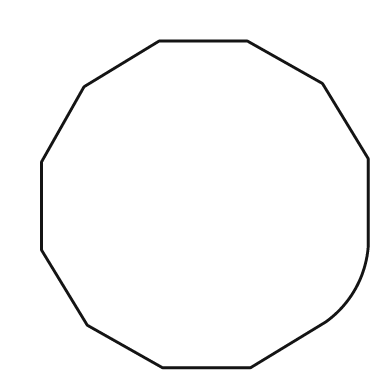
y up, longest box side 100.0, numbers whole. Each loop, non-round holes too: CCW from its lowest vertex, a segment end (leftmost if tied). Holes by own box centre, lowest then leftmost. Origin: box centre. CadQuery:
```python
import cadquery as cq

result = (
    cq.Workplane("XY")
    .moveTo(-13.0, -50.0)
    .lineTo(14.0, -50.0)
    .lineTo(37.0, -36.0)
    .threePointArc((46.0, -26.0), (50.0, -13.0))
    .lineTo(50.0, 14.0)
    .lineTo(36.0, 37.0)
    .lineTo(13.0, 50.0)
    .lineTo(-14.0, 50.0)
    .lineTo(-37.0, 36.0)
    .lineTo(-50.0, 13.0)
    .lineTo(-50.0, -14.0)
    .lineTo(-36.0, -37.0)
    .close()
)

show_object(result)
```